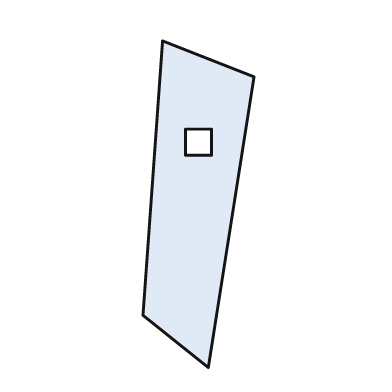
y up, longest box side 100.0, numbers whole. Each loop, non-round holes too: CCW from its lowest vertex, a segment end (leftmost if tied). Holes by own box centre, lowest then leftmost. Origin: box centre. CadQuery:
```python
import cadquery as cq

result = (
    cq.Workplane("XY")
    .moveTo(3.0, -50.0)
    .lineTo(17.0, 39.0)
    .lineTo(-11.0, 50.0)
    .lineTo(-17.0, -34.0)
    .close()
    .moveTo(-4.0, 15.0)
    .lineTo(4.0, 15.0)
    .lineTo(4.0, 23.0)
    .lineTo(-4.0, 23.0)
    .close()
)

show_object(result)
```